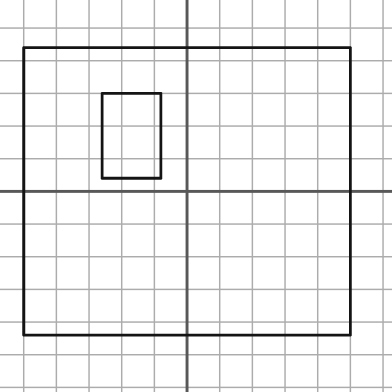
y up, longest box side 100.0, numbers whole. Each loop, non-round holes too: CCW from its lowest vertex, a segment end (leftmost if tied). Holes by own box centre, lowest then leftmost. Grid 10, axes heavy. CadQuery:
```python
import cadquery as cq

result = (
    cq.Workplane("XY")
    .moveTo(-50.0, -44.0)
    .lineTo(50.0, -44.0)
    .lineTo(50.0, 44.0)
    .lineTo(-50.0, 44.0)
    .close()
    .moveTo(-26.0, 4.0)
    .lineTo(-8.0, 4.0)
    .lineTo(-8.0, 30.0)
    .lineTo(-26.0, 30.0)
    .close()
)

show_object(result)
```